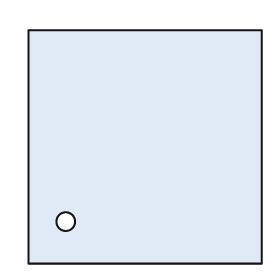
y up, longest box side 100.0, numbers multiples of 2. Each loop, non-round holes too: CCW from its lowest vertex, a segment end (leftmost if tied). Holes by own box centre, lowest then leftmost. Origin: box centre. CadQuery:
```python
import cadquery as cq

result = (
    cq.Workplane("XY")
    .moveTo(-50.0, -50.0)
    .lineTo(50.0, -50.0)
    .lineTo(50.0, 50.0)
    .lineTo(-50.0, 50.0)
    .close()
    .moveTo(-34.0, -32.0)
    .circle(4.0)
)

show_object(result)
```